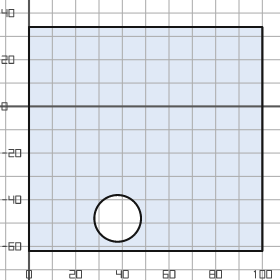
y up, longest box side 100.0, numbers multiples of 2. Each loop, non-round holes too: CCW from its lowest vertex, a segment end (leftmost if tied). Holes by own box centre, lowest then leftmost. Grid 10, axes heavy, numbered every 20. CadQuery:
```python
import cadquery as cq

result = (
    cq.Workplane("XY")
    .moveTo(0.0, -62.0)
    .lineTo(100.0, -62.0)
    .lineTo(100.0, 34.0)
    .lineTo(0.0, 34.0)
    .close()
    .moveTo(38.0, -48.0)
    .circle(10.0)
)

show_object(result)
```